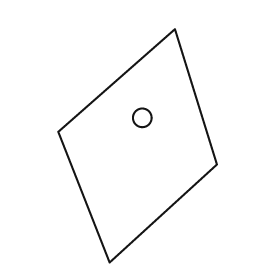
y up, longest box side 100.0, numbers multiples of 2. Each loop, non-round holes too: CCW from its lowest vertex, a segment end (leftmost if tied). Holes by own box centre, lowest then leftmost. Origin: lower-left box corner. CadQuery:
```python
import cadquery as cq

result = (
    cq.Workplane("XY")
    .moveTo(22.0, 0.0)
    .lineTo(68.0, 42.0)
    .lineTo(50.0, 100.0)
    .lineTo(0.0, 56.0)
    .close()
    .moveTo(36.0, 62.0)
    .circle(4.0)
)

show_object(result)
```